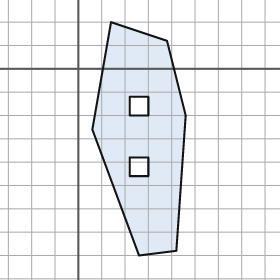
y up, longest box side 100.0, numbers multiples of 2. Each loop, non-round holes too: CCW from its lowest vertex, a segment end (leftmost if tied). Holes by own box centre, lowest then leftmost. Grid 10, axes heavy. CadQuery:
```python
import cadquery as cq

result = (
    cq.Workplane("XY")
    .moveTo(26.0, -80.0)
    .lineTo(42.0, -78.0)
    .lineTo(46.0, -20.0)
    .lineTo(38.0, 12.0)
    .lineTo(14.0, 20.0)
    .lineTo(6.0, -26.0)
    .close()
    .moveTo(22.0, -46.0)
    .lineTo(30.0, -46.0)
    .lineTo(30.0, -38.0)
    .lineTo(22.0, -38.0)
    .close()
    .moveTo(22.0, -20.0)
    .lineTo(30.0, -20.0)
    .lineTo(30.0, -12.0)
    .lineTo(22.0, -12.0)
    .close()
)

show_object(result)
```